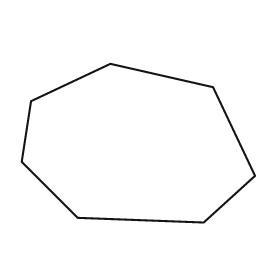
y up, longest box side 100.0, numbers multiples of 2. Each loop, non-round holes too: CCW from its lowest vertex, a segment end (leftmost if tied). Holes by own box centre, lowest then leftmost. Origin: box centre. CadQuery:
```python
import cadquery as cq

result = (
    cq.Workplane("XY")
    .moveTo(28.0, -34.0)
    .lineTo(50.0, -14.0)
    .lineTo(32.0, 24.0)
    .lineTo(-12.0, 34.0)
    .lineTo(-46.0, 18.0)
    .lineTo(-50.0, -8.0)
    .lineTo(-26.0, -32.0)
    .close()
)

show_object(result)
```